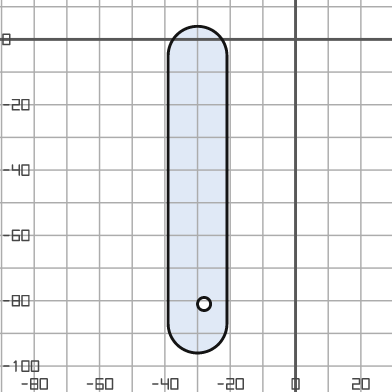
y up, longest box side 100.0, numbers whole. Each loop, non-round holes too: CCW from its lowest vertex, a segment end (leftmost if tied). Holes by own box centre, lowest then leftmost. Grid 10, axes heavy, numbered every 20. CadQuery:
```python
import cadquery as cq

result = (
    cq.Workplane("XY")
    .moveTo(-39.0, -87.0)
    .threePointArc((-30.0, -96.0), (-21.0, -87.0))
    .lineTo(-21.0, -5.0)
    .threePointArc((-30.0, 4.0), (-39.0, -5.0))
    .close()
    .moveTo(-28.0, -81.0)
    .circle(2.0)
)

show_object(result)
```